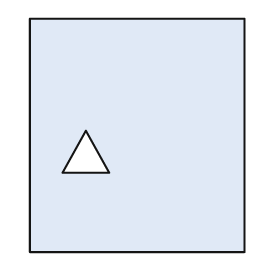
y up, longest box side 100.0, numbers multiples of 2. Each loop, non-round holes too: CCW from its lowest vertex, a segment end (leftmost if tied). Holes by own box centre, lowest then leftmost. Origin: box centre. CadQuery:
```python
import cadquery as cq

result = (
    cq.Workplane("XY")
    .moveTo(-46.0, -50.0)
    .lineTo(46.0, -50.0)
    .lineTo(46.0, 50.0)
    .lineTo(-46.0, 50.0)
    .close()
    .moveTo(-32.0, -16.0)
    .lineTo(-12.0, -16.0)
    .lineTo(-22.0, 2.0)
    .close()
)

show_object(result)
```